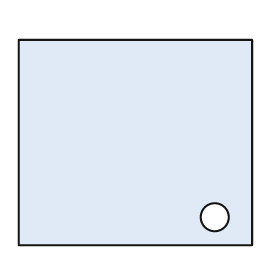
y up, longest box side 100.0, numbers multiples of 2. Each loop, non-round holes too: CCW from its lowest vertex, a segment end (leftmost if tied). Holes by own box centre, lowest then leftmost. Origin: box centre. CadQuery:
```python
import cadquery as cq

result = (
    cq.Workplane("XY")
    .moveTo(-50.0, -44.0)
    .lineTo(50.0, -44.0)
    .lineTo(50.0, 44.0)
    .lineTo(-50.0, 44.0)
    .close()
    .moveTo(34.0, -32.0)
    .circle(6.0)
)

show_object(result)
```